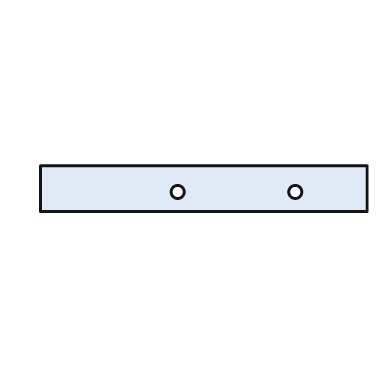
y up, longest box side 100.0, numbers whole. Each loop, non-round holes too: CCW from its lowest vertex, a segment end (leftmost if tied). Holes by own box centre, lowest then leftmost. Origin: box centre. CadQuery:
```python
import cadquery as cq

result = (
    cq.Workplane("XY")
    .moveTo(-50.0, -7.0)
    .lineTo(50.0, -7.0)
    .lineTo(50.0, 7.0)
    .lineTo(-50.0, 7.0)
    .close()
    .moveTo(-8.0, -1.0)
    .circle(2.0)
    .moveTo(28.0, -1.0)
    .circle(2.0)
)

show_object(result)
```